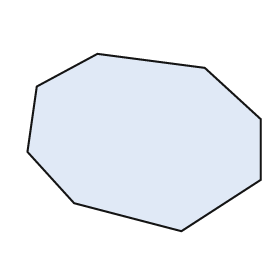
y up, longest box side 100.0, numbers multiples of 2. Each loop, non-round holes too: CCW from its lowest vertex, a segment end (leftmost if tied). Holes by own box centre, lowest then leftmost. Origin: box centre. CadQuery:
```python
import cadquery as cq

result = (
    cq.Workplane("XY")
    .moveTo(16.0, -38.0)
    .lineTo(50.0, -16.0)
    .lineTo(50.0, 10.0)
    .lineTo(26.0, 32.0)
    .lineTo(-20.0, 38.0)
    .lineTo(-46.0, 24.0)
    .lineTo(-50.0, -4.0)
    .lineTo(-30.0, -26.0)
    .close()
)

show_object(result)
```